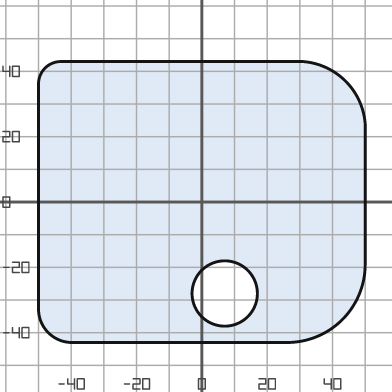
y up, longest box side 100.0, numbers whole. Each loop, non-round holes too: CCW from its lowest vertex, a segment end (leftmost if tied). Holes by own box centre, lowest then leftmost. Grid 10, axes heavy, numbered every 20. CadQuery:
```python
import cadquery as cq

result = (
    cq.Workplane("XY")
    .moveTo(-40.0, -43.0)
    .lineTo(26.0, -43.0)
    .threePointArc((43.0, -36.0), (50.0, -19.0))
    .lineTo(50.0, 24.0)
    .threePointArc((44.0, 37.0), (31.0, 43.0))
    .lineTo(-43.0, 43.0)
    .threePointArc((-48.0, 41.0), (-50.0, 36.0))
    .lineTo(-50.0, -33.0)
    .threePointArc((-47.0, -40.0), (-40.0, -43.0))
    .close()
    .moveTo(7.0, -28.0)
    .circle(10.0)
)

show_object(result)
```